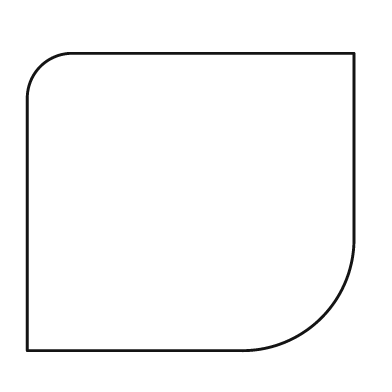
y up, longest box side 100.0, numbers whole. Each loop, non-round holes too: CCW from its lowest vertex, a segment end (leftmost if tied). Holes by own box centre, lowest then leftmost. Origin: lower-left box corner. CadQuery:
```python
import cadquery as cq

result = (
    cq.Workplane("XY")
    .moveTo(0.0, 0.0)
    .lineTo(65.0, 0.0)
    .threePointArc((90.0, 10.0), (100.0, 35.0))
    .lineTo(100.0, 91.0)
    .lineTo(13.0, 91.0)
    .threePointArc((4.0, 87.0), (0.0, 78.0))
    .close()
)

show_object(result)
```